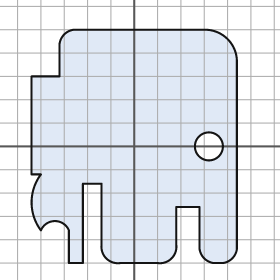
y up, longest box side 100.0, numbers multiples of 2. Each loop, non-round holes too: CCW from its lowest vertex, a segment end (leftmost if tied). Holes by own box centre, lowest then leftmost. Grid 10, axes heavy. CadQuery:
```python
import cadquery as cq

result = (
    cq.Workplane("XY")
    .moveTo(-28.0, -50.0)
    .lineTo(-22.0, -50.0)
    .lineTo(-22.0, -16.0)
    .lineTo(-14.0, -16.0)
    .lineTo(-14.0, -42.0)
    .threePointArc((-12.0, -48.0), (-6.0, -50.0))
    .lineTo(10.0, -50.0)
    .threePointArc((16.0, -48.0), (18.0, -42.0))
    .lineTo(18.0, -26.0)
    .lineTo(28.0, -26.0)
    .lineTo(28.0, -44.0)
    .threePointArc((30.0, -48.0), (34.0, -50.0))
    .lineTo(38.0, -50.0)
    .threePointArc((42.0, -48.0), (44.0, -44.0))
    .lineTo(44.0, 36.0)
    .threePointArc((40.0, 46.0), (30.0, 50.0))
    .lineTo(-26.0, 50.0)
    .threePointArc((-30.0, 48.0), (-32.0, 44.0))
    .lineTo(-32.0, 30.0)
    .lineTo(-44.0, 30.0)
    .lineTo(-44.0, -12.0)
    .lineTo(-40.0, -12.0)
    .threePointArc((-44.0, -24.0), (-40.0, -36.0))
    .threePointArc((-34.0, -32.0), (-28.0, -36.0))
    .close()
    .moveTo(32.0, 0.0)
    .circle(6.0)
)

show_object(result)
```